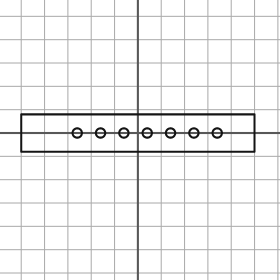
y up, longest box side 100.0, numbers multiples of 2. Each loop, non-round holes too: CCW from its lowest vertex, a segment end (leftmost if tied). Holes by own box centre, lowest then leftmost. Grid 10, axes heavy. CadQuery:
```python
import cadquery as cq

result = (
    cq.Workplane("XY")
    .moveTo(-50.0, -8.0)
    .lineTo(50.0, -8.0)
    .lineTo(50.0, 8.0)
    .lineTo(-50.0, 8.0)
    .close()
    .moveTo(-26.0, 0.0)
    .circle(2.0)
    .moveTo(-16.0, 0.0)
    .circle(2.0)
    .moveTo(-6.0, 0.0)
    .circle(2.0)
    .moveTo(4.0, 0.0)
    .circle(2.0)
    .moveTo(14.0, 0.0)
    .circle(2.0)
    .moveTo(24.0, 0.0)
    .circle(2.0)
    .moveTo(34.0, 0.0)
    .circle(2.0)
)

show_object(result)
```